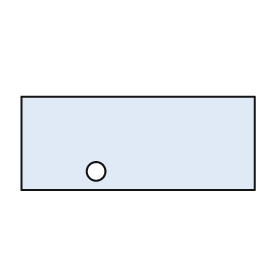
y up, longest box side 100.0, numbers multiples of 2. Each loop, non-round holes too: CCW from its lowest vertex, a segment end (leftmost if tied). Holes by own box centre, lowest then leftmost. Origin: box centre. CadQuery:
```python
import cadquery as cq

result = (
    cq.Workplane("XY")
    .moveTo(-50.0, -20.0)
    .lineTo(50.0, -20.0)
    .lineTo(50.0, 20.0)
    .lineTo(-50.0, 20.0)
    .close()
    .moveTo(-18.0, -12.0)
    .circle(4.0)
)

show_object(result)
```